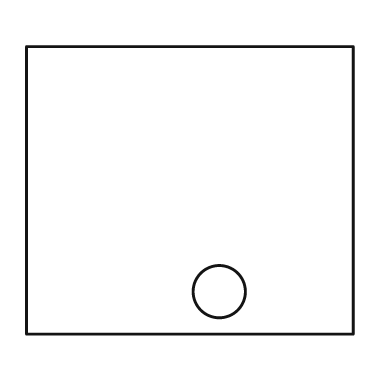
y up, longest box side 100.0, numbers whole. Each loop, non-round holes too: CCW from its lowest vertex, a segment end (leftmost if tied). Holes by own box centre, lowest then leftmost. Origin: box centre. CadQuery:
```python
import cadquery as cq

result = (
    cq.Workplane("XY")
    .moveTo(-50.0, -44.0)
    .lineTo(50.0, -44.0)
    .lineTo(50.0, 44.0)
    .lineTo(-50.0, 44.0)
    .close()
    .moveTo(9.0, -31.0)
    .circle(8.0)
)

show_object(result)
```